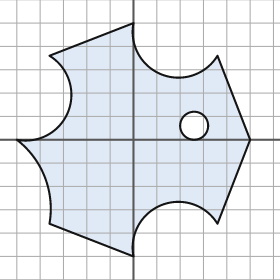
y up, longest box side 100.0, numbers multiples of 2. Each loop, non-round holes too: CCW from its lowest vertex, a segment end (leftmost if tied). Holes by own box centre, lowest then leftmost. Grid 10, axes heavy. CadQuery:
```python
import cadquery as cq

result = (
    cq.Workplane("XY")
    .moveTo(0.0, -50.0)
    .threePointArc((12.0, -28.0), (36.0, -36.0))
    .lineTo(50.0, 0.0)
    .lineTo(36.0, 36.0)
    .threePointArc((12.0, 28.0), (0.0, 50.0))
    .lineTo(-36.0, 36.0)
    .threePointArc((-28.0, 12.0), (-50.0, 0.0))
    .threePointArc((-38.0, -16.0), (-36.0, -36.0))
    .close()
    .moveTo(26.0, 6.0)
    .circle(6.0)
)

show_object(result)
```